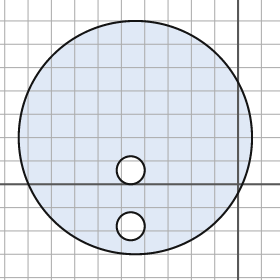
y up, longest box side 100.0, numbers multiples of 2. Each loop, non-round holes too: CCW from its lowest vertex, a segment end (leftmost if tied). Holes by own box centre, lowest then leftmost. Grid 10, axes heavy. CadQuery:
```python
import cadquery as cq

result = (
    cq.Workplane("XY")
    .moveTo(-44.0, 20.0)
    .circle(50.0)
    .moveTo(-46.0, -18.0)
    .circle(6.0)
    .moveTo(-46.0, 6.0)
    .circle(6.0)
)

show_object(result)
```